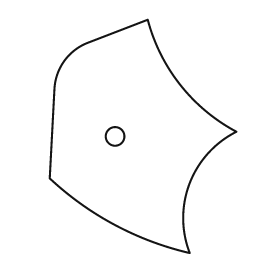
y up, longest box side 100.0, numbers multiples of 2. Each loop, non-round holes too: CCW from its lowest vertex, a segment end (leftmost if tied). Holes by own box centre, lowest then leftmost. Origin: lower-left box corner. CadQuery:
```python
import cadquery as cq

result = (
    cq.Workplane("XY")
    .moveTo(60.0, 0.0)
    .threePointArc((60.0, 30.0), (80.0, 52.0))
    .threePointArc((56.0, 72.0), (42.0, 100.0))
    .lineTo(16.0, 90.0)
    .threePointArc((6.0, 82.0), (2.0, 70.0))
    .lineTo(0.0, 32.0)
    .threePointArc((28.0, 12.0), (60.0, 0.0))
    .close()
    .moveTo(28.0, 50.0)
    .circle(4.0)
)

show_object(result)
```